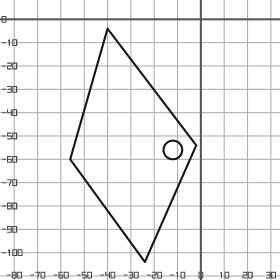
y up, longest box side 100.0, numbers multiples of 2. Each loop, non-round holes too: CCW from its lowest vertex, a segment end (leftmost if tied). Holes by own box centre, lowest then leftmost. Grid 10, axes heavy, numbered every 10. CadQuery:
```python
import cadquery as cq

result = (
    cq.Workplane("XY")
    .moveTo(-24.0, -104.0)
    .lineTo(-2.0, -54.0)
    .lineTo(-40.0, -4.0)
    .lineTo(-56.0, -60.0)
    .close()
    .moveTo(-12.0, -56.0)
    .circle(4.0)
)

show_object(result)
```